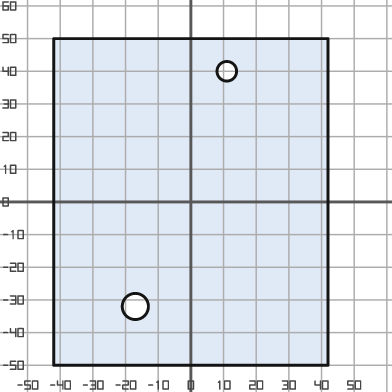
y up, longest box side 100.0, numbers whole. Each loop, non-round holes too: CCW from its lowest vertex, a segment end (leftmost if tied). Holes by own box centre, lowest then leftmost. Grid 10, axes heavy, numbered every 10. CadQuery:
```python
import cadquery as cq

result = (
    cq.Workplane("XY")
    .moveTo(-42.0, -50.0)
    .lineTo(42.0, -50.0)
    .lineTo(42.0, 50.0)
    .lineTo(-42.0, 50.0)
    .close()
    .moveTo(-17.0, -32.0)
    .circle(4.0)
    .moveTo(11.0, 40.0)
    .circle(3.0)
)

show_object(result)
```